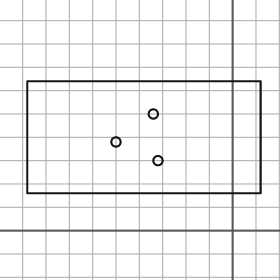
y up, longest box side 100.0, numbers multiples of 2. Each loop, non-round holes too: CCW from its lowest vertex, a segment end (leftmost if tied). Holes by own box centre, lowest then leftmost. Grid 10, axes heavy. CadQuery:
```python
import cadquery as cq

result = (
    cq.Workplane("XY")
    .moveTo(-88.0, 16.0)
    .lineTo(12.0, 16.0)
    .lineTo(12.0, 64.0)
    .lineTo(-88.0, 64.0)
    .close()
    .moveTo(-32.0, 30.0)
    .circle(2.0)
    .moveTo(-50.0, 38.0)
    .circle(2.0)
    .moveTo(-34.0, 50.0)
    .circle(2.0)
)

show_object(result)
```